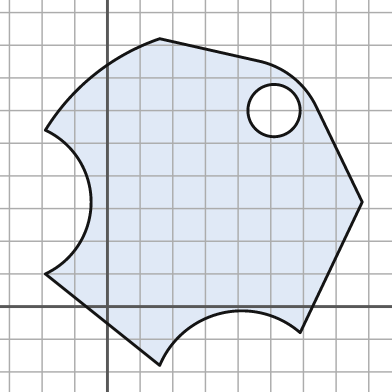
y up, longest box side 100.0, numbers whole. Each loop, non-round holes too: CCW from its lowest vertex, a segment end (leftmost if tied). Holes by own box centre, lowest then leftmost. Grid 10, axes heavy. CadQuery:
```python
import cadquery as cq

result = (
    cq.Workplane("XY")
    .moveTo(16.0, -18.0)
    .threePointArc((35.0, -2.0), (59.0, -8.0))
    .lineTo(78.0, 32.0)
    .lineTo(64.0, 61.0)
    .threePointArc((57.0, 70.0), (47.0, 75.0))
    .lineTo(16.0, 82.0)
    .threePointArc((-4.0, 71.0), (-19.0, 54.0))
    .threePointArc((-5.0, 32.0), (-19.0, 10.0))
    .close()
    .moveTo(51.0, 60.0)
    .circle(8.0)
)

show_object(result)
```